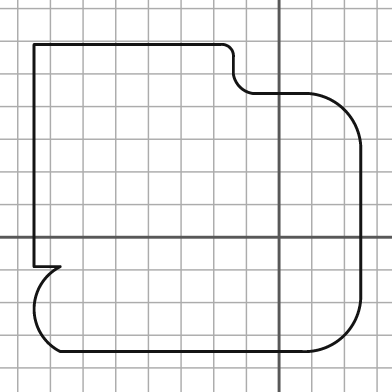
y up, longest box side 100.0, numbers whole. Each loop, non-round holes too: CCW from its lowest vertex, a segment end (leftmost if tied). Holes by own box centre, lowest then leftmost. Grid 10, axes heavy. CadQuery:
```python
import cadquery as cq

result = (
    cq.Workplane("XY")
    .moveTo(-67.0, -35.0)
    .lineTo(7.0, -35.0)
    .threePointArc((20.0, -30.0), (25.0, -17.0))
    .lineTo(25.0, 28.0)
    .threePointArc((20.0, 39.0), (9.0, 44.0))
    .lineTo(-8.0, 44.0)
    .threePointArc((-12.0, 46.0), (-14.0, 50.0))
    .lineTo(-14.0, 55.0)
    .threePointArc((-15.0, 58.0), (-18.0, 59.0))
    .lineTo(-75.0, 59.0)
    .lineTo(-75.0, -9.0)
    .lineTo(-67.0, -9.0)
    .threePointArc((-75.0, -22.0), (-67.0, -35.0))
    .close()
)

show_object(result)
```